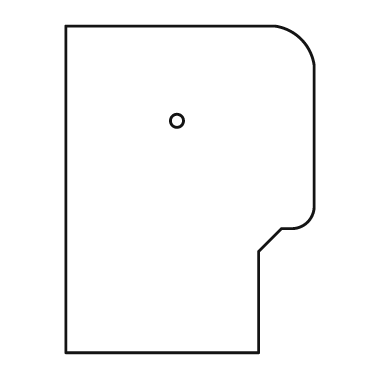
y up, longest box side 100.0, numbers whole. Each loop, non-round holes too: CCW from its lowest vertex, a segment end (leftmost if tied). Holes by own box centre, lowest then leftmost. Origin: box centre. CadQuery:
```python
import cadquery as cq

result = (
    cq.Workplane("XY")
    .moveTo(-38.0, -50.0)
    .lineTo(21.0, -50.0)
    .lineTo(21.0, -19.0)
    .lineTo(28.0, -12.0)
    .lineTo(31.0, -12.0)
    .threePointArc((36.0, -10.0), (38.0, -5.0))
    .lineTo(38.0, 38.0)
    .threePointArc((34.0, 46.0), (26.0, 50.0))
    .lineTo(-38.0, 50.0)
    .close()
    .moveTo(-4.0, 21.0)
    .circle(2.0)
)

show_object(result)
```